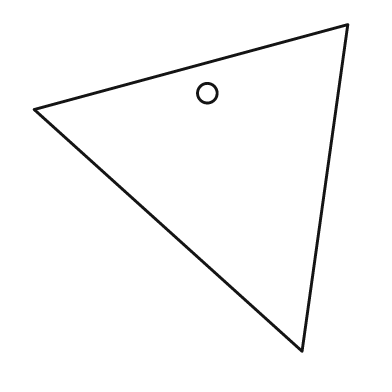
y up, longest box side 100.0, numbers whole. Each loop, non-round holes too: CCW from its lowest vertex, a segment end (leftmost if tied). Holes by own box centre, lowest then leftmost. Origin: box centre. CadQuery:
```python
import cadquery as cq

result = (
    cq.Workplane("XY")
    .moveTo(34.0, -50.0)
    .lineTo(48.0, 50.0)
    .lineTo(-48.0, 24.0)
    .close()
    .moveTo(5.0, 29.0)
    .circle(3.0)
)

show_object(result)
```